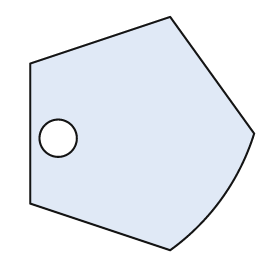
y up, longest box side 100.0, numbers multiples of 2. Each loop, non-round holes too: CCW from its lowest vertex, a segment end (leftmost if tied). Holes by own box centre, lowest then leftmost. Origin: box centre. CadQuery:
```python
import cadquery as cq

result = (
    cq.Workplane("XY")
    .moveTo(12.0, -50.0)
    .threePointArc((34.0, -28.0), (48.0, 0.0))
    .lineTo(12.0, 50.0)
    .lineTo(-48.0, 30.0)
    .lineTo(-48.0, -30.0)
    .close()
    .moveTo(-36.0, -2.0)
    .circle(8.0)
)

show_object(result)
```